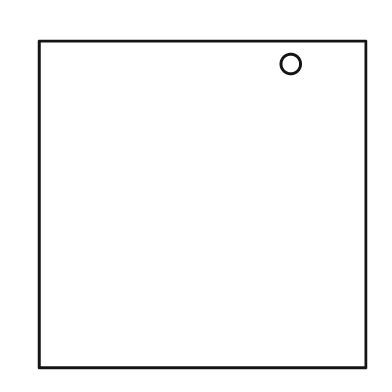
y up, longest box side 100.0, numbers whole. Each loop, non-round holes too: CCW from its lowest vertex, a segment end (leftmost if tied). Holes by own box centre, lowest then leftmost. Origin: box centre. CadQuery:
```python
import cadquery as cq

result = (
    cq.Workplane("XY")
    .moveTo(-50.0, -50.0)
    .lineTo(50.0, -50.0)
    .lineTo(50.0, 50.0)
    .lineTo(-50.0, 50.0)
    .close()
    .moveTo(27.0, 43.0)
    .circle(3.0)
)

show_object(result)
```